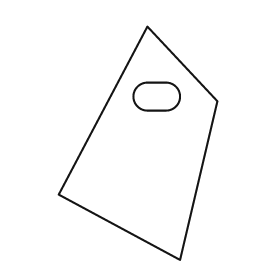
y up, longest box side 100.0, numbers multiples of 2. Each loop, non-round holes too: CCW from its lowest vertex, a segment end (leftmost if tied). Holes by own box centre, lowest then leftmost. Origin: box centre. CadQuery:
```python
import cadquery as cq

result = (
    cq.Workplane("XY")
    .moveTo(18.0, -50.0)
    .lineTo(34.0, 18.0)
    .lineTo(4.0, 50.0)
    .lineTo(-34.0, -22.0)
    .close()
    .moveTo(4.0, 14.0)
    .lineTo(12.0, 14.0)
    .threePointArc((18.0, 20.0), (12.0, 26.0))
    .lineTo(4.0, 26.0)
    .threePointArc((-2.0, 20.0), (4.0, 14.0))
    .close()
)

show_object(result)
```